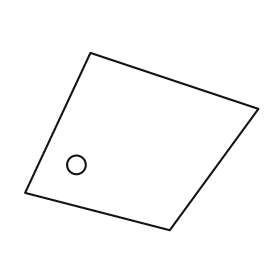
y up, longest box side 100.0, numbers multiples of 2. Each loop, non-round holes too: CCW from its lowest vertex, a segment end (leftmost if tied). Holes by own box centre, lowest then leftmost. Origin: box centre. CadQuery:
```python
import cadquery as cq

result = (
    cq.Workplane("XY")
    .moveTo(12.0, -38.0)
    .lineTo(50.0, 14.0)
    .lineTo(-22.0, 38.0)
    .lineTo(-50.0, -22.0)
    .close()
    .moveTo(-28.0, -10.0)
    .circle(4.0)
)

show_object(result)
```